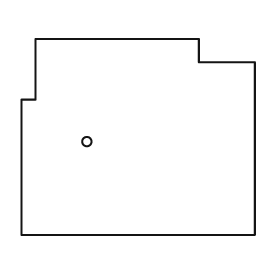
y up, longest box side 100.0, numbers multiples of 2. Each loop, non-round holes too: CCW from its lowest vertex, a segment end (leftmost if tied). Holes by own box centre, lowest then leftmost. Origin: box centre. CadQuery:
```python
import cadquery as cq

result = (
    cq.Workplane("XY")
    .moveTo(-50.0, -42.0)
    .lineTo(50.0, -42.0)
    .lineTo(50.0, 32.0)
    .lineTo(26.0, 32.0)
    .lineTo(26.0, 42.0)
    .lineTo(-44.0, 42.0)
    .lineTo(-44.0, 16.0)
    .lineTo(-50.0, 16.0)
    .close()
    .moveTo(-22.0, -2.0)
    .circle(2.0)
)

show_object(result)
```